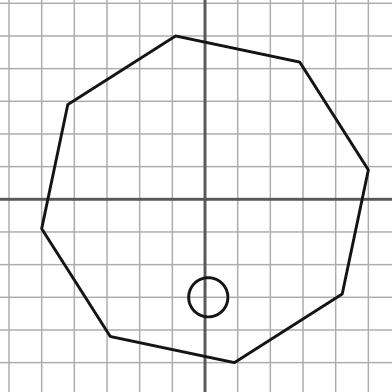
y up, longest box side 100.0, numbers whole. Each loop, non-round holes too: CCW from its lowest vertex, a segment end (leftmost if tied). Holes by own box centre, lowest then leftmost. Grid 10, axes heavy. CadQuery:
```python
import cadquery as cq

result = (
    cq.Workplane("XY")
    .moveTo(9.0, -50.0)
    .lineTo(42.0, -29.0)
    .lineTo(50.0, 9.0)
    .lineTo(29.0, 42.0)
    .lineTo(-9.0, 50.0)
    .lineTo(-42.0, 29.0)
    .lineTo(-50.0, -9.0)
    .lineTo(-29.0, -42.0)
    .close()
    .moveTo(1.0, -30.0)
    .circle(6.0)
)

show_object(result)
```